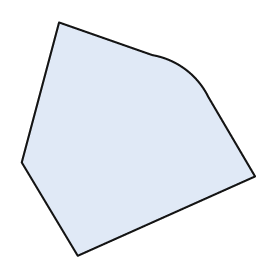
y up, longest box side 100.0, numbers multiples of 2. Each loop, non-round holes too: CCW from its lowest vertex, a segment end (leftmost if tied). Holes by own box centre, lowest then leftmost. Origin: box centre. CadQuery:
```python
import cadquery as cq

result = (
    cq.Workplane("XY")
    .moveTo(-26.0, -50.0)
    .lineTo(50.0, -16.0)
    .lineTo(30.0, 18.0)
    .threePointArc((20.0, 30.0), (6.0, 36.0))
    .lineTo(-34.0, 50.0)
    .lineTo(-50.0, -10.0)
    .close()
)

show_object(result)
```